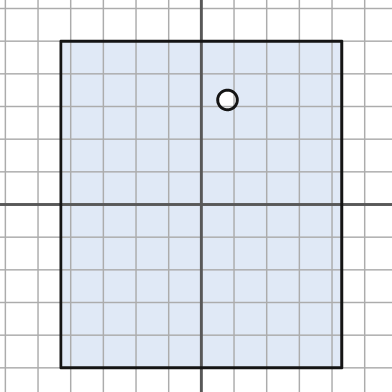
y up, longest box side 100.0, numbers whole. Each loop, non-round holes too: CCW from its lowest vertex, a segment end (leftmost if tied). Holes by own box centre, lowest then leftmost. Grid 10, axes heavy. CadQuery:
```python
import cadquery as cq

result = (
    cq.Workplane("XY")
    .moveTo(-43.0, -50.0)
    .lineTo(43.0, -50.0)
    .lineTo(43.0, 50.0)
    .lineTo(-43.0, 50.0)
    .close()
    .moveTo(8.0, 32.0)
    .circle(3.0)
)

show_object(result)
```